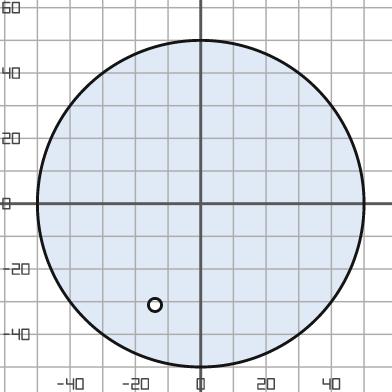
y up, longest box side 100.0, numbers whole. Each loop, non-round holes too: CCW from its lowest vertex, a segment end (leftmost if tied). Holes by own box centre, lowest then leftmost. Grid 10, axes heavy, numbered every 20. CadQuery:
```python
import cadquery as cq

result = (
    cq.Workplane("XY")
    .moveTo(0.0, 0.0)
    .circle(50.0)
    .moveTo(-14.0, -31.0)
    .circle(2.0)
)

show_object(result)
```